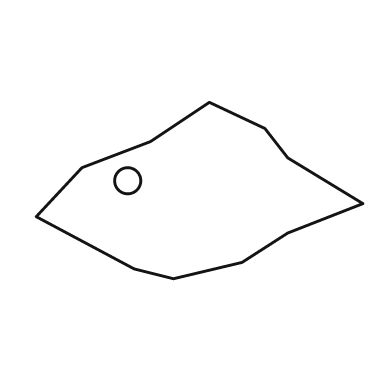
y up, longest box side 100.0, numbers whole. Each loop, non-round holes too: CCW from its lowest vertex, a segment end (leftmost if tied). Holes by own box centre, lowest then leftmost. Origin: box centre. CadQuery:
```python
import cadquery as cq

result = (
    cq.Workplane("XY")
    .moveTo(-8.0, -27.0)
    .lineTo(13.0, -22.0)
    .lineTo(27.0, -13.0)
    .lineTo(50.0, -4.0)
    .lineTo(27.0, 10.0)
    .lineTo(20.0, 19.0)
    .lineTo(3.0, 27.0)
    .lineTo(-15.0, 15.0)
    .lineTo(-36.0, 7.0)
    .lineTo(-50.0, -8.0)
    .lineTo(-20.0, -24.0)
    .close()
    .moveTo(-22.0, 3.0)
    .circle(4.0)
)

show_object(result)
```